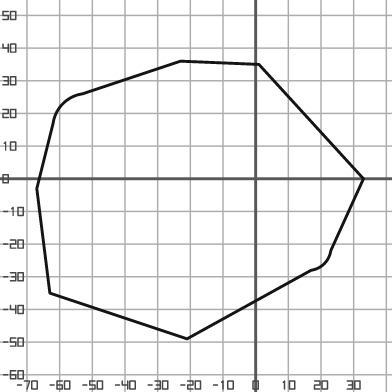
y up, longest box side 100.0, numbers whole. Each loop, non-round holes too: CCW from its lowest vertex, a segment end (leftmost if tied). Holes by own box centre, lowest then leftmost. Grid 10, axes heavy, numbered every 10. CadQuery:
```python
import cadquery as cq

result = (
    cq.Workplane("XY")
    .moveTo(-21.0, -49.0)
    .lineTo(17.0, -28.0)
    .threePointArc((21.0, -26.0), (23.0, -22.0))
    .lineTo(33.0, 0.0)
    .lineTo(1.0, 35.0)
    .lineTo(-23.0, 36.0)
    .lineTo(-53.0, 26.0)
    .threePointArc((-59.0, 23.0), (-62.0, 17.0))
    .lineTo(-67.0, -3.0)
    .lineTo(-63.0, -35.0)
    .close()
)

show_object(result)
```